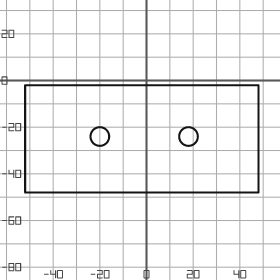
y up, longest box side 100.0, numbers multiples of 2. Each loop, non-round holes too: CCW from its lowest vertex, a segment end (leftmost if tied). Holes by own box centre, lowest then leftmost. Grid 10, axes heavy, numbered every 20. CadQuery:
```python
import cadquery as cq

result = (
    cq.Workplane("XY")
    .moveTo(-52.0, -48.0)
    .lineTo(48.0, -48.0)
    .lineTo(48.0, -2.0)
    .lineTo(-52.0, -2.0)
    .close()
    .moveTo(-20.0, -24.0)
    .circle(4.0)
    .moveTo(18.0, -24.0)
    .circle(4.0)
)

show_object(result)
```